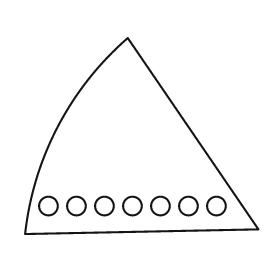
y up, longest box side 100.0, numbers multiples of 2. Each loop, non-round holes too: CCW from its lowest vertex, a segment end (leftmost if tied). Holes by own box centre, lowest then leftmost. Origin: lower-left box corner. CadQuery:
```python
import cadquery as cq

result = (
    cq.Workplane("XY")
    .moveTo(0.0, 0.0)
    .lineTo(100.0, 2.0)
    .lineTo(44.0, 84.0)
    .threePointArc((14.0, 46.0), (0.0, 0.0))
    .close()
    .moveTo(10.0, 12.0)
    .circle(4.0)
    .moveTo(22.0, 12.0)
    .circle(4.0)
    .moveTo(34.0, 12.0)
    .circle(4.0)
    .moveTo(46.0, 12.0)
    .circle(4.0)
    .moveTo(58.0, 12.0)
    .circle(4.0)
    .moveTo(70.0, 12.0)
    .circle(4.0)
    .moveTo(82.0, 12.0)
    .circle(4.0)
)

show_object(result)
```